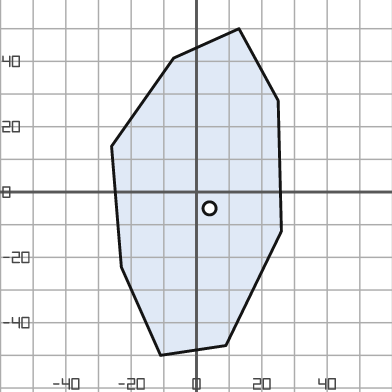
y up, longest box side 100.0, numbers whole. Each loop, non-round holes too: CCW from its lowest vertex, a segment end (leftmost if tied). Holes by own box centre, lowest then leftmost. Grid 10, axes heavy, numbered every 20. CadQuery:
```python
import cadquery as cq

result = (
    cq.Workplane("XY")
    .moveTo(-11.0, -50.0)
    .lineTo(9.0, -47.0)
    .lineTo(26.0, -12.0)
    .lineTo(25.0, 28.0)
    .lineTo(13.0, 50.0)
    .lineTo(-7.0, 41.0)
    .lineTo(-26.0, 14.0)
    .lineTo(-23.0, -23.0)
    .close()
    .moveTo(4.0, -5.0)
    .circle(2.0)
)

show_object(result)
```